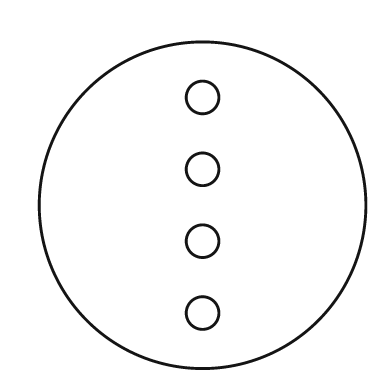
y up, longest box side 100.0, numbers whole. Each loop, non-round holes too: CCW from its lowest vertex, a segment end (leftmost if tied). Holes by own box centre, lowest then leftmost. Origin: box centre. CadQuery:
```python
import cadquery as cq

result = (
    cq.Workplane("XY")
    .moveTo(0.0, 0.0)
    .circle(50.0)
    .moveTo(0.0, -33.0)
    .circle(5.0)
    .moveTo(0.0, -11.0)
    .circle(5.0)
    .moveTo(0.0, 11.0)
    .circle(5.0)
    .moveTo(0.0, 33.0)
    .circle(5.0)
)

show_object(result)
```